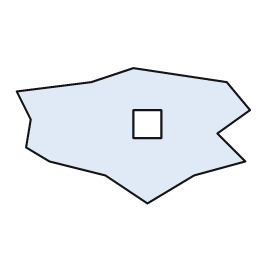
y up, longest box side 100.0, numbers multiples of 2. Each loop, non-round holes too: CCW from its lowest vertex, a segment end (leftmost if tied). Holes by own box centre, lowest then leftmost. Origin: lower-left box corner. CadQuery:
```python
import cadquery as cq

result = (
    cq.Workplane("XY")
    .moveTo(56.0, 0.0)
    .lineTo(76.0, 12.0)
    .lineTo(98.0, 18.0)
    .lineTo(86.0, 30.0)
    .lineTo(100.0, 40.0)
    .lineTo(90.0, 52.0)
    .lineTo(50.0, 58.0)
    .lineTo(32.0, 52.0)
    .lineTo(0.0, 48.0)
    .lineTo(6.0, 36.0)
    .lineTo(4.0, 24.0)
    .lineTo(14.0, 18.0)
    .lineTo(38.0, 12.0)
    .close()
    .moveTo(50.0, 28.0)
    .lineTo(62.0, 28.0)
    .lineTo(62.0, 40.0)
    .lineTo(50.0, 40.0)
    .close()
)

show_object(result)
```